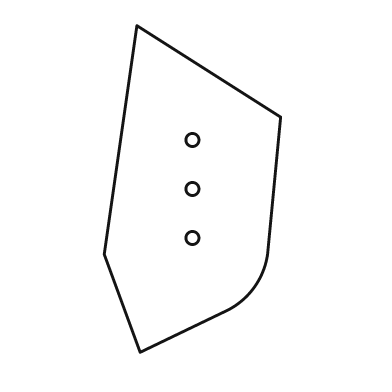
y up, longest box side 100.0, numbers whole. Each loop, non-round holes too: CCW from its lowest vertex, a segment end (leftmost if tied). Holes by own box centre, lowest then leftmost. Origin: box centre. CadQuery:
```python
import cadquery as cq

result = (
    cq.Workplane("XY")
    .moveTo(-16.0, -50.0)
    .lineTo(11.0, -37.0)
    .threePointArc((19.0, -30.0), (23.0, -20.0))
    .lineTo(27.0, 22.0)
    .lineTo(-17.0, 50.0)
    .lineTo(-27.0, -20.0)
    .close()
    .moveTo(0.0, -15.0)
    .circle(2.0)
    .moveTo(0.0, 0.0)
    .circle(2.0)
    .moveTo(0.0, 15.0)
    .circle(2.0)
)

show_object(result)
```